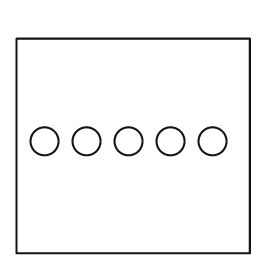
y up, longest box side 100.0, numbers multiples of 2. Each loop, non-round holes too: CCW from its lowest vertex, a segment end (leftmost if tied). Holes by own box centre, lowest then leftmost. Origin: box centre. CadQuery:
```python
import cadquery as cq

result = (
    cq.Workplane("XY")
    .moveTo(-50.0, -46.0)
    .lineTo(50.0, -46.0)
    .lineTo(50.0, 46.0)
    .lineTo(-50.0, 46.0)
    .close()
    .moveTo(-38.0, 2.0)
    .circle(6.0)
    .moveTo(-20.0, 2.0)
    .circle(6.0)
    .moveTo(-2.0, 2.0)
    .circle(6.0)
    .moveTo(16.0, 2.0)
    .circle(6.0)
    .moveTo(34.0, 2.0)
    .circle(6.0)
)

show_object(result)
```